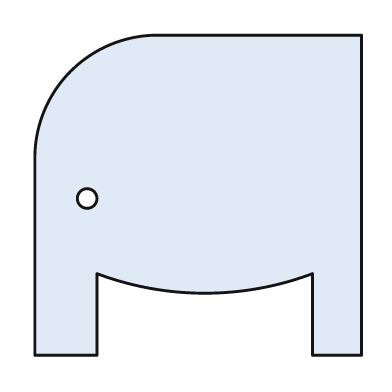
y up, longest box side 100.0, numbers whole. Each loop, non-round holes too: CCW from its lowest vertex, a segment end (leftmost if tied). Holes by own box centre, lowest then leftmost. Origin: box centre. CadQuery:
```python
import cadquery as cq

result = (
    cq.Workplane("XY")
    .moveTo(-50.0, -49.0)
    .lineTo(-31.0, -49.0)
    .lineTo(-31.0, -24.0)
    .threePointArc((2.0, -30.0), (35.0, -24.0))
    .lineTo(35.0, -49.0)
    .lineTo(50.0, -49.0)
    .lineTo(50.0, 49.0)
    .lineTo(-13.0, 49.0)
    .threePointArc((-39.0, 38.0), (-50.0, 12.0))
    .close()
    .moveTo(-34.0, -1.0)
    .circle(3.0)
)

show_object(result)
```